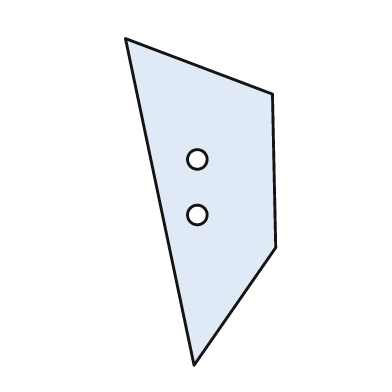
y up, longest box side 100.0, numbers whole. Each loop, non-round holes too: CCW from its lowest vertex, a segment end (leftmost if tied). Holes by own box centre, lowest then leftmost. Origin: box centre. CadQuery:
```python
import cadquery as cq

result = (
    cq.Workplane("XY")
    .moveTo(-2.0, -50.0)
    .lineTo(23.0, -14.0)
    .lineTo(22.0, 33.0)
    .lineTo(-23.0, 50.0)
    .close()
    .moveTo(-1.0, -4.0)
    .circle(3.0)
    .moveTo(-1.0, 13.0)
    .circle(3.0)
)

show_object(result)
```